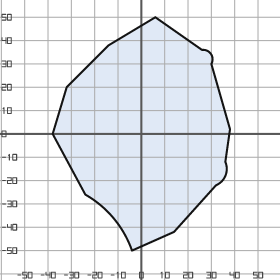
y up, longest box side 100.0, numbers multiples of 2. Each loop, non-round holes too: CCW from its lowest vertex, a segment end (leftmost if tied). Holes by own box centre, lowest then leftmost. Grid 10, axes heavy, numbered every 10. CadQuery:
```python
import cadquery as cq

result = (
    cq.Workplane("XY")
    .moveTo(-4.0, -50.0)
    .lineTo(14.0, -42.0)
    .lineTo(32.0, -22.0)
    .threePointArc((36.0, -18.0), (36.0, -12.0))
    .lineTo(38.0, 2.0)
    .lineTo(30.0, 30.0)
    .threePointArc((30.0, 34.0), (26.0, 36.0))
    .lineTo(6.0, 50.0)
    .lineTo(-14.0, 38.0)
    .lineTo(-32.0, 20.0)
    .lineTo(-38.0, 0.0)
    .lineTo(-24.0, -26.0)
    .threePointArc((-12.0, -36.0), (-4.0, -50.0))
    .close()
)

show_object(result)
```